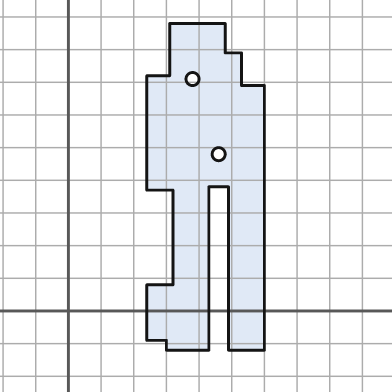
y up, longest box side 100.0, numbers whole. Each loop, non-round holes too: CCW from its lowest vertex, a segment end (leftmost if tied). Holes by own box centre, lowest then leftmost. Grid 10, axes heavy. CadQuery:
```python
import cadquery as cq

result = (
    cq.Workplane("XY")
    .moveTo(30.0, -12.0)
    .lineTo(43.0, -12.0)
    .lineTo(43.0, 38.0)
    .lineTo(49.0, 38.0)
    .lineTo(49.0, -12.0)
    .lineTo(60.0, -12.0)
    .lineTo(60.0, 69.0)
    .lineTo(53.0, 69.0)
    .lineTo(53.0, 79.0)
    .lineTo(48.0, 79.0)
    .lineTo(48.0, 88.0)
    .lineTo(31.0, 88.0)
    .lineTo(31.0, 72.0)
    .lineTo(24.0, 72.0)
    .lineTo(24.0, 37.0)
    .lineTo(32.0, 37.0)
    .lineTo(32.0, 8.0)
    .lineTo(24.0, 8.0)
    .lineTo(24.0, -9.0)
    .lineTo(30.0, -9.0)
    .close()
    .moveTo(46.0, 48.0)
    .circle(2.0)
    .moveTo(38.0, 71.0)
    .circle(2.0)
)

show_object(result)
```